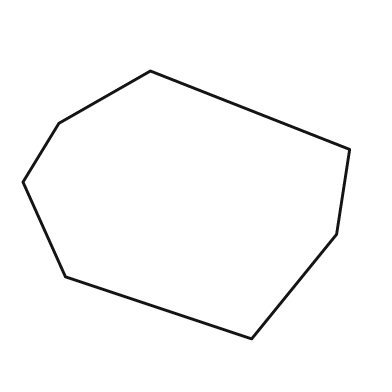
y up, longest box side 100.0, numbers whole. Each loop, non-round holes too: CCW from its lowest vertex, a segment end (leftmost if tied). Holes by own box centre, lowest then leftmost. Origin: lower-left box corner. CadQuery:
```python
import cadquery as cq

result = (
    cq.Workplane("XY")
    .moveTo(70.0, 0.0)
    .lineTo(96.0, 32.0)
    .lineTo(100.0, 58.0)
    .lineTo(39.0, 82.0)
    .lineTo(11.0, 66.0)
    .lineTo(0.0, 48.0)
    .lineTo(13.0, 19.0)
    .close()
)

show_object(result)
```